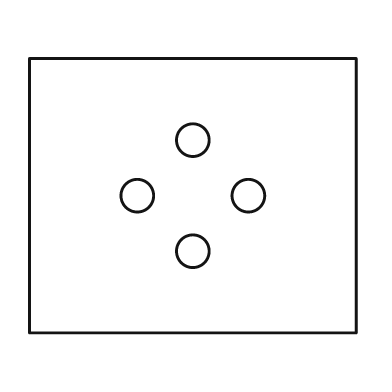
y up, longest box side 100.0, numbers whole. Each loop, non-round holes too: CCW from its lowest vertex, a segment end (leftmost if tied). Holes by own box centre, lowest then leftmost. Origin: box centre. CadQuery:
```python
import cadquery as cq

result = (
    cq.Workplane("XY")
    .moveTo(-50.0, -42.0)
    .lineTo(50.0, -42.0)
    .lineTo(50.0, 42.0)
    .lineTo(-50.0, 42.0)
    .close()
    .moveTo(0.0, -17.0)
    .circle(5.0)
    .moveTo(-17.0, 0.0)
    .circle(5.0)
    .moveTo(17.0, 0.0)
    .circle(5.0)
    .moveTo(0.0, 17.0)
    .circle(5.0)
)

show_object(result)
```